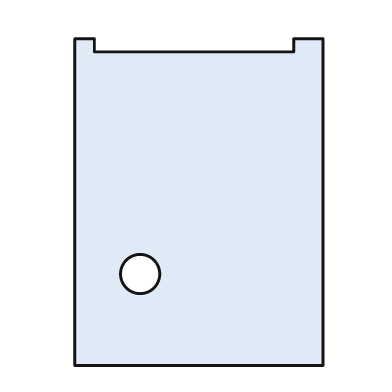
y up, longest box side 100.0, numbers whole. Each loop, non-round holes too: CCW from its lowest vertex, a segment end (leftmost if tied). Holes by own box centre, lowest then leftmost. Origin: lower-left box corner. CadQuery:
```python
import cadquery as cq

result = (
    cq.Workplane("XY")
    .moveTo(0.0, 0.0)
    .lineTo(76.0, 0.0)
    .lineTo(76.0, 100.0)
    .lineTo(67.0, 100.0)
    .lineTo(67.0, 96.0)
    .lineTo(6.0, 96.0)
    .lineTo(6.0, 100.0)
    .lineTo(0.0, 100.0)
    .close()
    .moveTo(20.0, 28.0)
    .circle(6.0)
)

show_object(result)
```